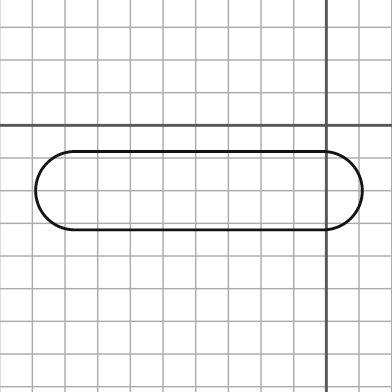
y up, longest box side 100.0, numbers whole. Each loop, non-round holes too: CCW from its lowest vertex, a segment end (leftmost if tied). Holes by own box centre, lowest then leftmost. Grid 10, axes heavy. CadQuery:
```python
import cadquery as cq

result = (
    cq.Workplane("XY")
    .moveTo(-77.0, -32.0)
    .lineTo(-1.0, -32.0)
    .threePointArc((11.0, -20.0), (-1.0, -8.0))
    .lineTo(-77.0, -8.0)
    .threePointArc((-89.0, -20.0), (-77.0, -32.0))
    .close()
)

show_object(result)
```